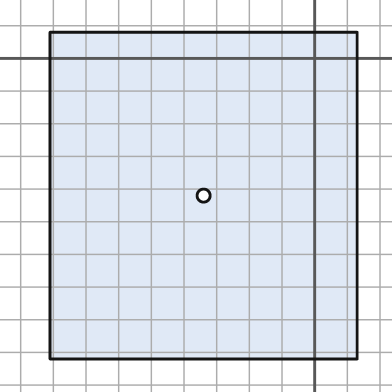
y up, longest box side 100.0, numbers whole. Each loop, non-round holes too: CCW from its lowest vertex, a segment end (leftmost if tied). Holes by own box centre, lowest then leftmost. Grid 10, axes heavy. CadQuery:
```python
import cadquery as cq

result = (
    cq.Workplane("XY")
    .moveTo(-81.0, -92.0)
    .lineTo(13.0, -92.0)
    .lineTo(13.0, 8.0)
    .lineTo(-81.0, 8.0)
    .close()
    .moveTo(-34.0, -42.0)
    .circle(2.0)
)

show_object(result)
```